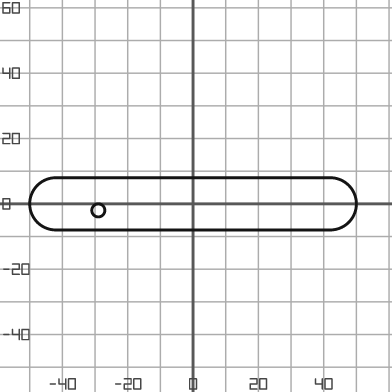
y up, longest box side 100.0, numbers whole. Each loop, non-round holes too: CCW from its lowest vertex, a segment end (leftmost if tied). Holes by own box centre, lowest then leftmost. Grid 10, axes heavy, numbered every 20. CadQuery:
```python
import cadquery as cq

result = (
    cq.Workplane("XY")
    .moveTo(-42.0, -8.0)
    .lineTo(42.0, -8.0)
    .threePointArc((50.0, 0.0), (42.0, 8.0))
    .lineTo(-42.0, 8.0)
    .threePointArc((-50.0, 0.0), (-42.0, -8.0))
    .close()
    .moveTo(-29.0, -2.0)
    .circle(2.0)
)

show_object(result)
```